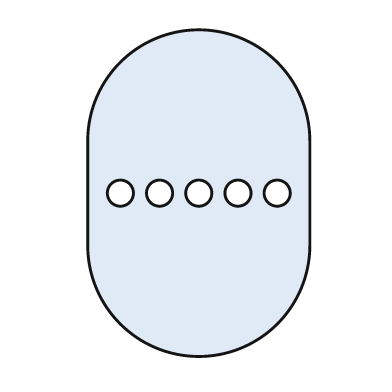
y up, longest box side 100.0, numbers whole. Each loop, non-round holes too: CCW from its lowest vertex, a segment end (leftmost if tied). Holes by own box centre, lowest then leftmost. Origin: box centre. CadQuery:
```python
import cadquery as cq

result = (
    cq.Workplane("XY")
    .moveTo(-34.0, -16.0)
    .threePointArc((0.0, -50.0), (34.0, -16.0))
    .lineTo(34.0, 16.0)
    .threePointArc((0.0, 50.0), (-34.0, 16.0))
    .close()
    .moveTo(-24.0, 0.0)
    .circle(4.0)
    .moveTo(-12.0, 0.0)
    .circle(4.0)
    .moveTo(0.0, 0.0)
    .circle(4.0)
    .moveTo(12.0, 0.0)
    .circle(4.0)
    .moveTo(24.0, 0.0)
    .circle(4.0)
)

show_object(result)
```